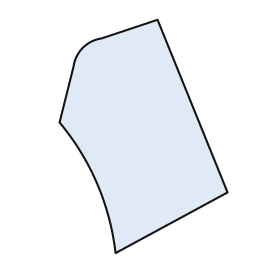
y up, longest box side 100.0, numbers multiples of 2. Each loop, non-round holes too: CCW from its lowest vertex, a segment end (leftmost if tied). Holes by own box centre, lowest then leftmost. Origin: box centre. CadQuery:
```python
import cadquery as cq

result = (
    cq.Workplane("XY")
    .moveTo(-12.0, -50.0)
    .lineTo(36.0, -24.0)
    .lineTo(6.0, 50.0)
    .lineTo(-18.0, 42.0)
    .threePointArc((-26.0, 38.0), (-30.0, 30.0))
    .lineTo(-36.0, 6.0)
    .threePointArc((-20.0, -20.0), (-12.0, -50.0))
    .close()
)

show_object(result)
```